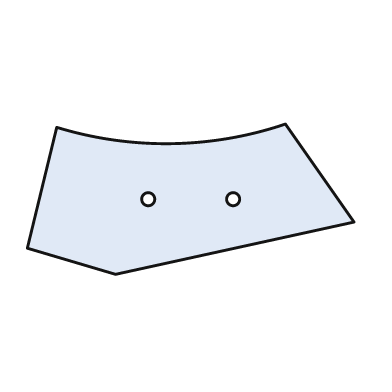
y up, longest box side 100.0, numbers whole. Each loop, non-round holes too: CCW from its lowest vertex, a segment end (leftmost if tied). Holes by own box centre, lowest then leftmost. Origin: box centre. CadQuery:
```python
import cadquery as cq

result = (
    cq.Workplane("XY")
    .moveTo(-23.0, -23.0)
    .lineTo(50.0, -7.0)
    .lineTo(29.0, 23.0)
    .threePointArc((-6.0, 17.0), (-41.0, 22.0))
    .lineTo(-50.0, -15.0)
    .close()
    .moveTo(-13.0, 0.0)
    .circle(2.0)
    .moveTo(13.0, 0.0)
    .circle(2.0)
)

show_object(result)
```